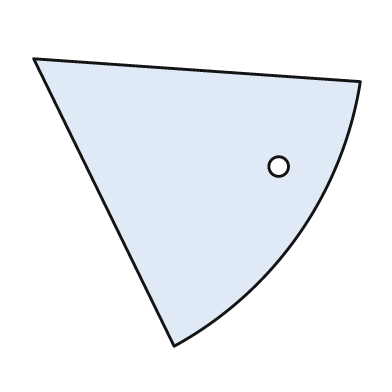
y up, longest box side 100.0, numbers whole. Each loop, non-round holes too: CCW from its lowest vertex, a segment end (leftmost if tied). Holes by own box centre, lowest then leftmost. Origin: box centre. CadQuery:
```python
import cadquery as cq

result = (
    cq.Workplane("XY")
    .moveTo(-7.0, -44.0)
    .threePointArc((31.0, -10.0), (50.0, 37.0))
    .lineTo(-50.0, 44.0)
    .close()
    .moveTo(25.0, 11.0)
    .circle(3.0)
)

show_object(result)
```